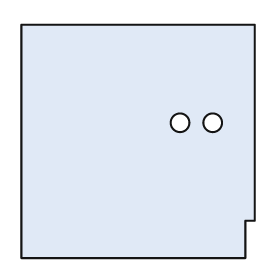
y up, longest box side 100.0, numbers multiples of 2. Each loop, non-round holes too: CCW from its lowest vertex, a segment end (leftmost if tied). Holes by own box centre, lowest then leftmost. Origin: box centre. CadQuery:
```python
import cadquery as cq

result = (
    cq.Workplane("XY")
    .moveTo(-50.0, -50.0)
    .lineTo(46.0, -50.0)
    .lineTo(46.0, -34.0)
    .lineTo(50.0, -34.0)
    .lineTo(50.0, 50.0)
    .lineTo(-50.0, 50.0)
    .close()
    .moveTo(18.0, 8.0)
    .circle(4.0)
    .moveTo(32.0, 8.0)
    .circle(4.0)
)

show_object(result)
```